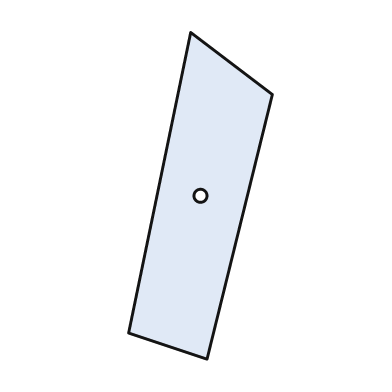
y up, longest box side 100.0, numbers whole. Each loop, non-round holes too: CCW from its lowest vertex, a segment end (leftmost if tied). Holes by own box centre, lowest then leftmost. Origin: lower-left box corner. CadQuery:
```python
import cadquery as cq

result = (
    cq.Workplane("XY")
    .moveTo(24.0, 0.0)
    .lineTo(44.0, 81.0)
    .lineTo(19.0, 100.0)
    .lineTo(0.0, 8.0)
    .close()
    .moveTo(22.0, 50.0)
    .circle(2.0)
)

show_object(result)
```